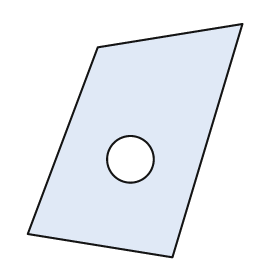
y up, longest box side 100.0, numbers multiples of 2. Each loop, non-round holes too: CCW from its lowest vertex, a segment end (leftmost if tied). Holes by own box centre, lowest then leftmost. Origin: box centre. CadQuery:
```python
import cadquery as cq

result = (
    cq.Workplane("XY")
    .moveTo(16.0, -50.0)
    .lineTo(46.0, 50.0)
    .lineTo(-16.0, 40.0)
    .lineTo(-46.0, -40.0)
    .close()
    .moveTo(-2.0, -8.0)
    .circle(10.0)
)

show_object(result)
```